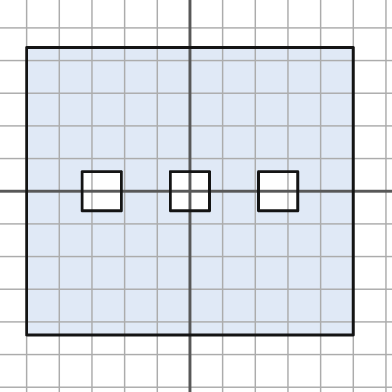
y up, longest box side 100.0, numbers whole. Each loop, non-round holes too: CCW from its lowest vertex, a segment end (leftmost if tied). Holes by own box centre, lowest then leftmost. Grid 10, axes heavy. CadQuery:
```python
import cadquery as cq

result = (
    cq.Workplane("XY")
    .moveTo(-50.0, -44.0)
    .lineTo(50.0, -44.0)
    .lineTo(50.0, 44.0)
    .lineTo(-50.0, 44.0)
    .close()
    .moveTo(-33.0, -6.0)
    .lineTo(-21.0, -6.0)
    .lineTo(-21.0, 6.0)
    .lineTo(-33.0, 6.0)
    .close()
    .moveTo(-6.0, -6.0)
    .lineTo(6.0, -6.0)
    .lineTo(6.0, 6.0)
    .lineTo(-6.0, 6.0)
    .close()
    .moveTo(21.0, -6.0)
    .lineTo(33.0, -6.0)
    .lineTo(33.0, 6.0)
    .lineTo(21.0, 6.0)
    .close()
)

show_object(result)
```